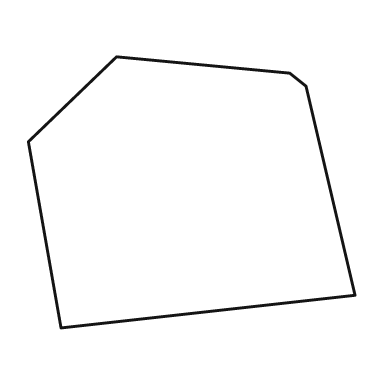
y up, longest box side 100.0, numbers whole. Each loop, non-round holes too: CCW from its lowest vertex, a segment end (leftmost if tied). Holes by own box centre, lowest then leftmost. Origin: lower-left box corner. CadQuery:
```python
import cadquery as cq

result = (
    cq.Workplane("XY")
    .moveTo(10.0, 0.0)
    .lineTo(100.0, 10.0)
    .lineTo(85.0, 74.0)
    .lineTo(80.0, 78.0)
    .lineTo(27.0, 83.0)
    .lineTo(0.0, 57.0)
    .close()
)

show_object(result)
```